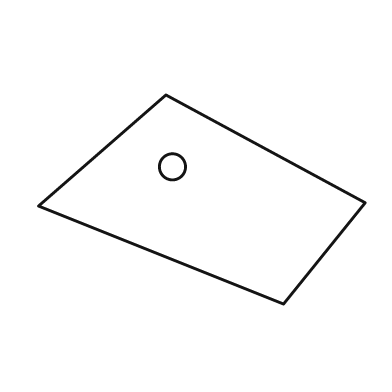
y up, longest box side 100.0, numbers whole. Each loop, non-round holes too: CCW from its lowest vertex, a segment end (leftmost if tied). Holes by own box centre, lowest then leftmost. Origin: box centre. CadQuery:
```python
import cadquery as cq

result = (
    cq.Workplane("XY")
    .moveTo(25.0, -32.0)
    .lineTo(50.0, -1.0)
    .lineTo(-11.0, 32.0)
    .lineTo(-50.0, -2.0)
    .close()
    .moveTo(-9.0, 10.0)
    .circle(4.0)
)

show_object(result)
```